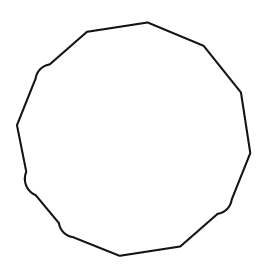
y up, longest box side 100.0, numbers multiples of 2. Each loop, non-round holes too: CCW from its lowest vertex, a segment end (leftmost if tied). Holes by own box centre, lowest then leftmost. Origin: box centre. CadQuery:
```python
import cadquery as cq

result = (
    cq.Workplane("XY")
    .moveTo(-6.0, -50.0)
    .lineTo(20.0, -46.0)
    .lineTo(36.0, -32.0)
    .threePointArc((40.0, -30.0), (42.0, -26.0))
    .lineTo(50.0, -6.0)
    .lineTo(46.0, 20.0)
    .lineTo(30.0, 40.0)
    .lineTo(6.0, 50.0)
    .lineTo(-20.0, 46.0)
    .lineTo(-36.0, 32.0)
    .threePointArc((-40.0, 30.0), (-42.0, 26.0))
    .lineTo(-50.0, 6.0)
    .lineTo(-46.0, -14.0)
    .threePointArc((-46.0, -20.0), (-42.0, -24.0))
    .lineTo(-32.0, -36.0)
    .threePointArc((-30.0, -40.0), (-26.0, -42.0))
    .close()
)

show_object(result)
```